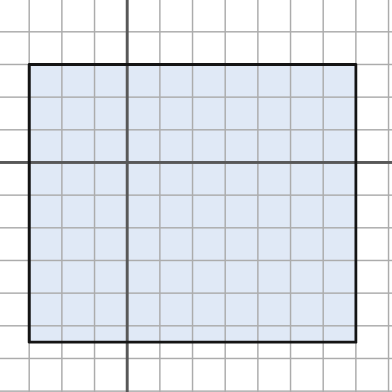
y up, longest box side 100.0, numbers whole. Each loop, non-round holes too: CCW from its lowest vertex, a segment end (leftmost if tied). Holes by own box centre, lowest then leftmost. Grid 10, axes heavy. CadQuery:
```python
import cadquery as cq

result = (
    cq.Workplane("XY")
    .moveTo(-30.0, -55.0)
    .lineTo(70.0, -55.0)
    .lineTo(70.0, 30.0)
    .lineTo(-30.0, 30.0)
    .close()
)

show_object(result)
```